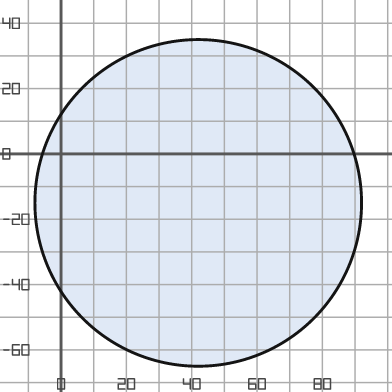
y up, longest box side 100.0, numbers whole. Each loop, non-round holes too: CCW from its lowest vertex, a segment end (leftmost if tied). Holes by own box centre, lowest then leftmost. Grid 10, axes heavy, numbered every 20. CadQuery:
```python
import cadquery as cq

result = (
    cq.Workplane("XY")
    .moveTo(42.0, -15.0)
    .circle(50.0)
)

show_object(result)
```